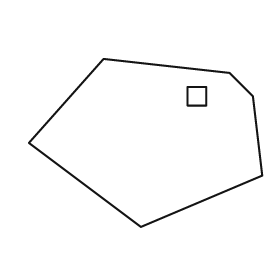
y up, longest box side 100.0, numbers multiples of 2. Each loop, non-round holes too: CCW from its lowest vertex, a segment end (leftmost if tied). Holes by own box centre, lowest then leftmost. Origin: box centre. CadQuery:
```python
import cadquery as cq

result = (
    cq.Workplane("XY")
    .moveTo(-2.0, -36.0)
    .lineTo(50.0, -14.0)
    .lineTo(46.0, 20.0)
    .lineTo(36.0, 30.0)
    .lineTo(-18.0, 36.0)
    .lineTo(-50.0, 0.0)
    .close()
    .moveTo(18.0, 16.0)
    .lineTo(26.0, 16.0)
    .lineTo(26.0, 24.0)
    .lineTo(18.0, 24.0)
    .close()
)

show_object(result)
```